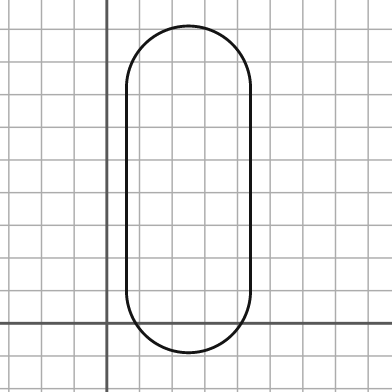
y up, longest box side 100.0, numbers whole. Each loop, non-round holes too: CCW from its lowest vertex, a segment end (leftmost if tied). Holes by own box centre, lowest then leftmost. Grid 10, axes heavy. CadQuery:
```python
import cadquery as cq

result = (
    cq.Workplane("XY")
    .moveTo(6.0, 10.0)
    .threePointArc((25.0, -9.0), (44.0, 10.0))
    .lineTo(44.0, 72.0)
    .threePointArc((25.0, 91.0), (6.0, 72.0))
    .close()
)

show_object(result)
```